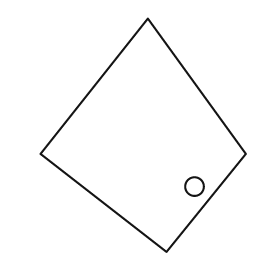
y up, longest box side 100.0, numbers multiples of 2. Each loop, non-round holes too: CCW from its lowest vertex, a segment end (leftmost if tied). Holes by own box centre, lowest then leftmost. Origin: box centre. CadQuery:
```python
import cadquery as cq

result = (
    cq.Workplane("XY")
    .moveTo(10.0, -50.0)
    .lineTo(44.0, -8.0)
    .lineTo(2.0, 50.0)
    .lineTo(-44.0, -8.0)
    .close()
    .moveTo(22.0, -22.0)
    .circle(4.0)
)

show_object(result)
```